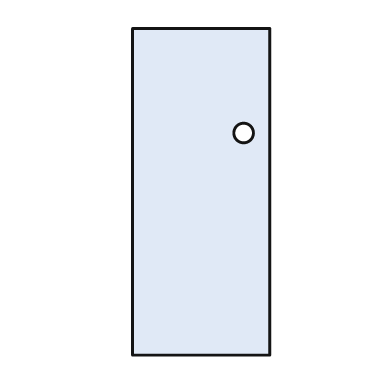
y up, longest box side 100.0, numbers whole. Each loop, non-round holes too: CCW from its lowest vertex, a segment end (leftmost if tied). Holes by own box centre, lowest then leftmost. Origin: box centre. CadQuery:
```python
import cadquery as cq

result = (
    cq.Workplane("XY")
    .moveTo(-21.0, -50.0)
    .lineTo(21.0, -50.0)
    .lineTo(21.0, 50.0)
    .lineTo(-21.0, 50.0)
    .close()
    .moveTo(13.0, 18.0)
    .circle(3.0)
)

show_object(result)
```